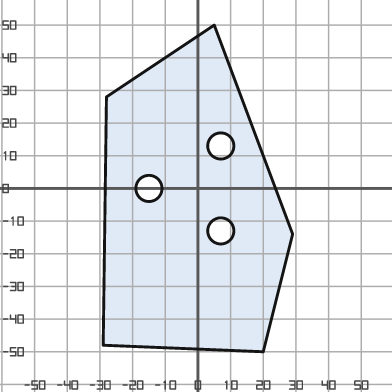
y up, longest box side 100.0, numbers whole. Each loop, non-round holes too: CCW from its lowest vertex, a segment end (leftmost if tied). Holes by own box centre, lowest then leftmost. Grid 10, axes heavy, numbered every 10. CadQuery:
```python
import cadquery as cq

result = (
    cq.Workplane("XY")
    .moveTo(20.0, -50.0)
    .lineTo(29.0, -14.0)
    .lineTo(5.0, 50.0)
    .lineTo(-28.0, 28.0)
    .lineTo(-29.0, -48.0)
    .close()
    .moveTo(7.0, -13.0)
    .circle(4.0)
    .moveTo(-15.0, 0.0)
    .circle(4.0)
    .moveTo(7.0, 13.0)
    .circle(4.0)
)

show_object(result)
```